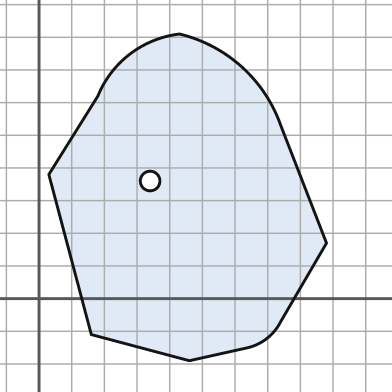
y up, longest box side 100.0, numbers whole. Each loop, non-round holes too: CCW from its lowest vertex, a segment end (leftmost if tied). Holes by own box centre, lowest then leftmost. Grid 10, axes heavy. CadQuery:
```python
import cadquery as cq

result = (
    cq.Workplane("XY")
    .moveTo(46.0, -19.0)
    .lineTo(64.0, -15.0)
    .threePointArc((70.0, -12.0), (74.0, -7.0))
    .lineTo(88.0, 17.0)
    .lineTo(74.0, 53.0)
    .threePointArc((62.0, 71.0), (43.0, 81.0))
    .threePointArc((28.0, 75.0), (18.0, 62.0))
    .lineTo(3.0, 38.0)
    .lineTo(16.0, -11.0)
    .close()
    .moveTo(34.0, 36.0)
    .circle(3.0)
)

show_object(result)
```